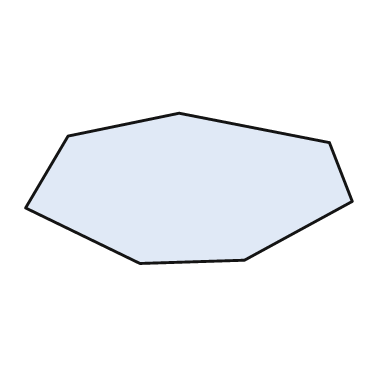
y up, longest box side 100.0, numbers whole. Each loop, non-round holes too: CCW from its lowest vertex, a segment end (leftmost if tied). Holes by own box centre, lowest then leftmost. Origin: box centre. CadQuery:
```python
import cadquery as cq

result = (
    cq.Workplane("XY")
    .moveTo(-15.0, -23.0)
    .lineTo(17.0, -22.0)
    .lineTo(50.0, -4.0)
    .lineTo(43.0, 14.0)
    .lineTo(-3.0, 23.0)
    .lineTo(-37.0, 16.0)
    .lineTo(-50.0, -6.0)
    .close()
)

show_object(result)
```